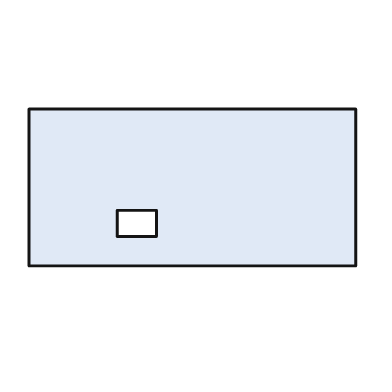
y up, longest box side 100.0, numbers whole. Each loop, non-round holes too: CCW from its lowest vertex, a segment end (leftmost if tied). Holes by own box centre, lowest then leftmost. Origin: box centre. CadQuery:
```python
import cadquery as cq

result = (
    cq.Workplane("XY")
    .moveTo(-50.0, -24.0)
    .lineTo(50.0, -24.0)
    .lineTo(50.0, 24.0)
    .lineTo(-50.0, 24.0)
    .close()
    .moveTo(-23.0, -15.0)
    .lineTo(-11.0, -15.0)
    .lineTo(-11.0, -7.0)
    .lineTo(-23.0, -7.0)
    .close()
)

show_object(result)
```